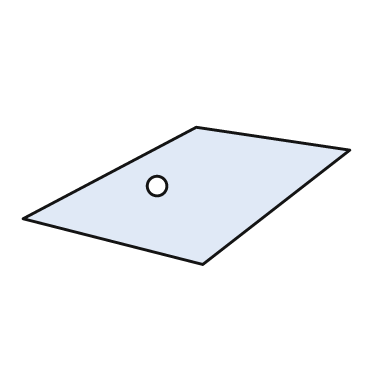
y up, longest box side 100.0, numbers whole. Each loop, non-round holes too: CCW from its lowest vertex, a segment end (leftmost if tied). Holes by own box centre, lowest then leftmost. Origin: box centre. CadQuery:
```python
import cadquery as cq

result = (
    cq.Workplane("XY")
    .moveTo(5.0, -21.0)
    .lineTo(50.0, 14.0)
    .lineTo(3.0, 21.0)
    .lineTo(-50.0, -7.0)
    .close()
    .moveTo(-9.0, 3.0)
    .circle(3.0)
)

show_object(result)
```